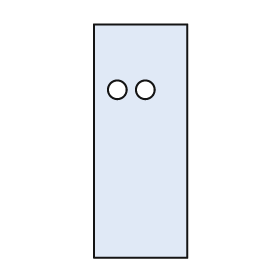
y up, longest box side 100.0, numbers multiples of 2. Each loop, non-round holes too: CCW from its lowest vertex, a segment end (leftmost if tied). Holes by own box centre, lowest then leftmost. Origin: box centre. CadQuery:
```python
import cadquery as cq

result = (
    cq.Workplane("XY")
    .moveTo(-20.0, -50.0)
    .lineTo(20.0, -50.0)
    .lineTo(20.0, 50.0)
    .lineTo(-20.0, 50.0)
    .close()
    .moveTo(-10.0, 22.0)
    .circle(4.0)
    .moveTo(2.0, 22.0)
    .circle(4.0)
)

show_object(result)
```